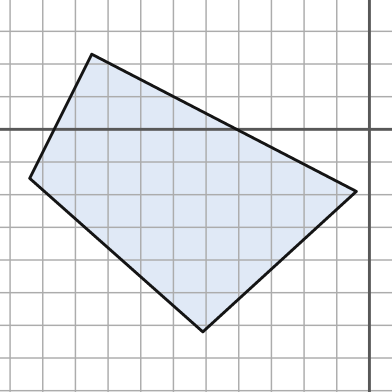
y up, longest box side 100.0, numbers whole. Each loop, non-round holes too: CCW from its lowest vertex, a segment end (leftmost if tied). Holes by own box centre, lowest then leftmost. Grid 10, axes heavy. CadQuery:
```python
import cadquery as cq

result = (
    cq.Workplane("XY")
    .moveTo(-51.0, -62.0)
    .lineTo(-4.0, -19.0)
    .lineTo(-85.0, 23.0)
    .lineTo(-104.0, -15.0)
    .close()
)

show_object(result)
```